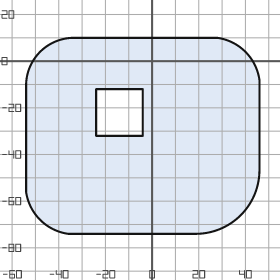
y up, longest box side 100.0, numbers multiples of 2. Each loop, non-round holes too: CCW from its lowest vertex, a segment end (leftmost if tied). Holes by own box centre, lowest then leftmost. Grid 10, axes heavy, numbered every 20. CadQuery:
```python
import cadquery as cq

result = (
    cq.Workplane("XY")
    .moveTo(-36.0, -74.0)
    .lineTo(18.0, -74.0)
    .threePointArc((38.0, -66.0), (46.0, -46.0))
    .lineTo(46.0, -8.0)
    .threePointArc((40.0, 4.0), (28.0, 10.0))
    .lineTo(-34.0, 10.0)
    .threePointArc((-48.0, 4.0), (-54.0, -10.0))
    .lineTo(-54.0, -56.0)
    .threePointArc((-48.0, -68.0), (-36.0, -74.0))
    .close()
    .moveTo(-24.0, -32.0)
    .lineTo(-4.0, -32.0)
    .lineTo(-4.0, -12.0)
    .lineTo(-24.0, -12.0)
    .close()
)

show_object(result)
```